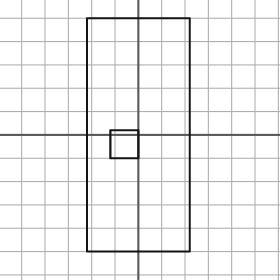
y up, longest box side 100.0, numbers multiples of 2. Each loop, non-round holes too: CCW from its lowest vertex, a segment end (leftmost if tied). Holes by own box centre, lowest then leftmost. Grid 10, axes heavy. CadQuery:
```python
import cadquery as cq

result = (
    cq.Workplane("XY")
    .moveTo(-22.0, -50.0)
    .lineTo(22.0, -50.0)
    .lineTo(22.0, 50.0)
    .lineTo(-22.0, 50.0)
    .close()
    .moveTo(-12.0, -10.0)
    .lineTo(0.0, -10.0)
    .lineTo(0.0, 2.0)
    .lineTo(-12.0, 2.0)
    .close()
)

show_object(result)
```